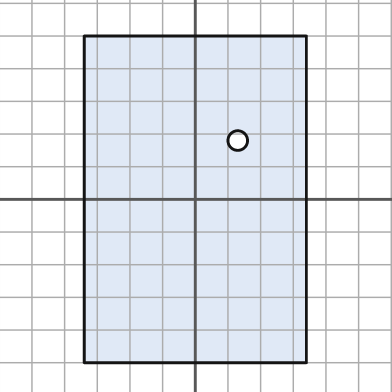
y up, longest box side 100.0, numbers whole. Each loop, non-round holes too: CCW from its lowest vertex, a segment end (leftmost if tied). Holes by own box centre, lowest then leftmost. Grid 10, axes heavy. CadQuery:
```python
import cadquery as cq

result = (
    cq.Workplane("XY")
    .moveTo(-34.0, -50.0)
    .lineTo(34.0, -50.0)
    .lineTo(34.0, 50.0)
    .lineTo(-34.0, 50.0)
    .close()
    .moveTo(13.0, 18.0)
    .circle(3.0)
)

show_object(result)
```